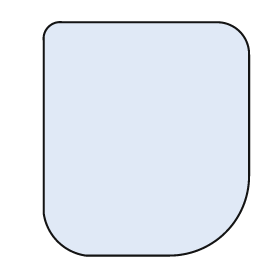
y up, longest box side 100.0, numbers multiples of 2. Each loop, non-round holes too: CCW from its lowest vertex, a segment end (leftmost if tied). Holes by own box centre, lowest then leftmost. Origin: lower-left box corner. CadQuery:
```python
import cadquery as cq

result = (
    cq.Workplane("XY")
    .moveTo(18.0, 0.0)
    .lineTo(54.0, 0.0)
    .threePointArc((78.0, 10.0), (88.0, 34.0))
    .lineTo(88.0, 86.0)
    .threePointArc((84.0, 96.0), (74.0, 100.0))
    .lineTo(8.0, 100.0)
    .threePointArc((2.0, 98.0), (0.0, 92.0))
    .lineTo(0.0, 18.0)
    .threePointArc((6.0, 6.0), (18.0, 0.0))
    .close()
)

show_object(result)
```